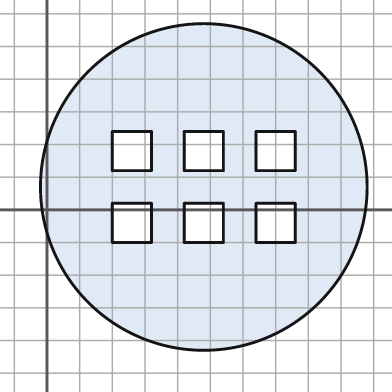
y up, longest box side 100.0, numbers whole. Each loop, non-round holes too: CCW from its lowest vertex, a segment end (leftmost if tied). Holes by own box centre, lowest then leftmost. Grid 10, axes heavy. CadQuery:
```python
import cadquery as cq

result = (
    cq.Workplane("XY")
    .moveTo(48.0, 7.0)
    .circle(50.0)
    .moveTo(20.0, -10.0)
    .lineTo(32.0, -10.0)
    .lineTo(32.0, 2.0)
    .lineTo(20.0, 2.0)
    .close()
    .moveTo(42.0, -10.0)
    .lineTo(54.0, -10.0)
    .lineTo(54.0, 2.0)
    .lineTo(42.0, 2.0)
    .close()
    .moveTo(64.0, -10.0)
    .lineTo(76.0, -10.0)
    .lineTo(76.0, 2.0)
    .lineTo(64.0, 2.0)
    .close()
    .moveTo(20.0, 12.0)
    .lineTo(32.0, 12.0)
    .lineTo(32.0, 24.0)
    .lineTo(20.0, 24.0)
    .close()
    .moveTo(42.0, 12.0)
    .lineTo(54.0, 12.0)
    .lineTo(54.0, 24.0)
    .lineTo(42.0, 24.0)
    .close()
    .moveTo(64.0, 12.0)
    .lineTo(76.0, 12.0)
    .lineTo(76.0, 24.0)
    .lineTo(64.0, 24.0)
    .close()
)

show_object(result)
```